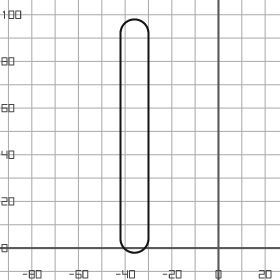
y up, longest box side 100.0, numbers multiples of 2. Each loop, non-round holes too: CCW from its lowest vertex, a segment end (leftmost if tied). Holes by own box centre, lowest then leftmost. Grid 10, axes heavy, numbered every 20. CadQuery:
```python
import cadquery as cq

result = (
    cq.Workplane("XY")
    .moveTo(-42.0, 4.0)
    .threePointArc((-36.0, -2.0), (-30.0, 4.0))
    .lineTo(-30.0, 92.0)
    .threePointArc((-36.0, 98.0), (-42.0, 92.0))
    .close()
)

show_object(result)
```